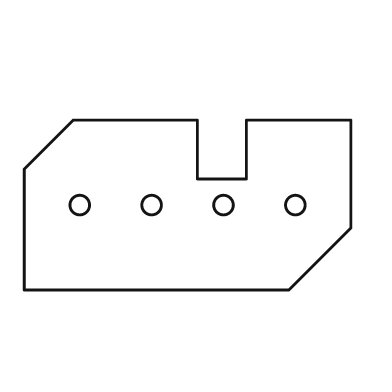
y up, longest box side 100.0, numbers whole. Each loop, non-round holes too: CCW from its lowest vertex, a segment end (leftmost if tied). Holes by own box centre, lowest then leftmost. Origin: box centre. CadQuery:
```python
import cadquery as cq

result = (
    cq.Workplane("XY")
    .moveTo(-50.0, -26.0)
    .lineTo(31.0, -26.0)
    .lineTo(50.0, -7.0)
    .lineTo(50.0, 26.0)
    .lineTo(18.0, 26.0)
    .lineTo(18.0, 8.0)
    .lineTo(3.0, 8.0)
    .lineTo(3.0, 26.0)
    .lineTo(-35.0, 26.0)
    .lineTo(-50.0, 11.0)
    .close()
    .moveTo(-33.0, 0.0)
    .circle(3.0)
    .moveTo(-11.0, 0.0)
    .circle(3.0)
    .moveTo(11.0, 0.0)
    .circle(3.0)
    .moveTo(33.0, 0.0)
    .circle(3.0)
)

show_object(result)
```